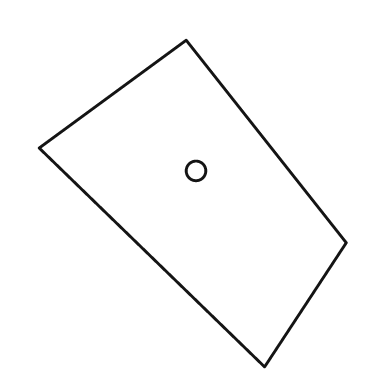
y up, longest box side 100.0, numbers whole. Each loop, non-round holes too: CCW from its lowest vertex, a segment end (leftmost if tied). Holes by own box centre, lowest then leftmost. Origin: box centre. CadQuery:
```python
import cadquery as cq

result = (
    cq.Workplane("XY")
    .moveTo(22.0, -50.0)
    .lineTo(47.0, -12.0)
    .lineTo(-2.0, 50.0)
    .lineTo(-47.0, 17.0)
    .close()
    .moveTo(1.0, 10.0)
    .circle(3.0)
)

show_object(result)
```